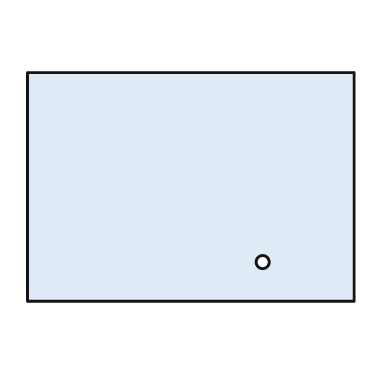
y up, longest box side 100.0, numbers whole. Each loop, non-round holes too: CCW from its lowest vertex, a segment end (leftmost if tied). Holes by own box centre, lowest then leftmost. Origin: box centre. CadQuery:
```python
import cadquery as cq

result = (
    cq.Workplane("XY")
    .moveTo(-50.0, -35.0)
    .lineTo(50.0, -35.0)
    .lineTo(50.0, 35.0)
    .lineTo(-50.0, 35.0)
    .close()
    .moveTo(22.0, -23.0)
    .circle(2.0)
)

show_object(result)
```